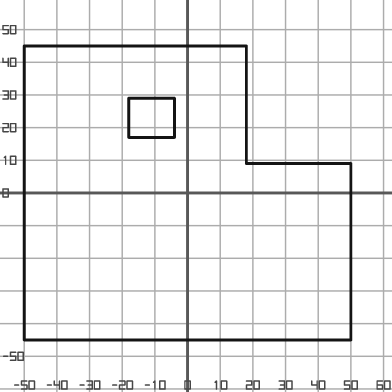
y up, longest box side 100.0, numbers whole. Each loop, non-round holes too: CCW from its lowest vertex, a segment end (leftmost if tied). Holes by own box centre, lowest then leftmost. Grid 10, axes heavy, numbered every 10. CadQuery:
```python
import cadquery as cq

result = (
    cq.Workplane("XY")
    .moveTo(-50.0, -45.0)
    .lineTo(50.0, -45.0)
    .lineTo(50.0, 9.0)
    .lineTo(18.0, 9.0)
    .lineTo(18.0, 45.0)
    .lineTo(-50.0, 45.0)
    .close()
    .moveTo(-18.0, 17.0)
    .lineTo(-4.0, 17.0)
    .lineTo(-4.0, 29.0)
    .lineTo(-18.0, 29.0)
    .close()
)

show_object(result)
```